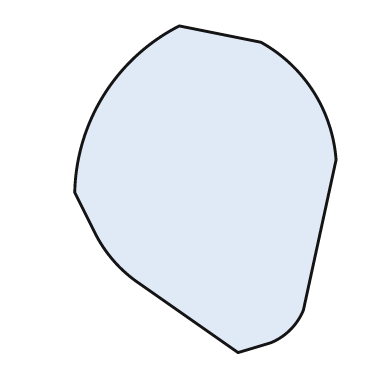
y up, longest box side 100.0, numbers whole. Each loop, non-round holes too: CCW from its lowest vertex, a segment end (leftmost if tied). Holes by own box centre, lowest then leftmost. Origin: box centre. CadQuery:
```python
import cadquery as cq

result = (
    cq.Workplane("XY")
    .moveTo(10.0, -50.0)
    .lineTo(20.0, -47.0)
    .threePointArc((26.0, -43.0), (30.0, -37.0))
    .lineTo(40.0, 9.0)
    .threePointArc((33.0, 30.0), (17.0, 45.0))
    .lineTo(-8.0, 50.0)
    .threePointArc((-31.0, 29.0), (-40.0, -1.0))
    .lineTo(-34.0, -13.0)
    .threePointArc((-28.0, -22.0), (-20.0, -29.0))
    .close()
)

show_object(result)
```